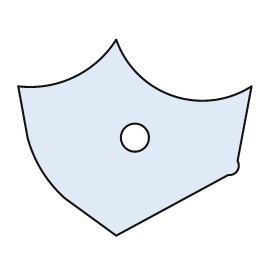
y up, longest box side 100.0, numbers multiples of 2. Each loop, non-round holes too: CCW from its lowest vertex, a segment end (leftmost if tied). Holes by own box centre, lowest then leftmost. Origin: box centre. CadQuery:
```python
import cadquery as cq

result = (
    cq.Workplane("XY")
    .moveTo(-8.0, -42.0)
    .lineTo(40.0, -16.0)
    .threePointArc((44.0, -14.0), (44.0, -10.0))
    .lineTo(50.0, 22.0)
    .threePointArc((16.0, 18.0), (-8.0, 42.0))
    .threePointArc((-26.0, 26.0), (-50.0, 22.0))
    .lineTo(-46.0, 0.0)
    .threePointArc((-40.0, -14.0), (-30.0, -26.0))
    .close()
    .moveTo(0.0, 0.0)
    .circle(6.0)
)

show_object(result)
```